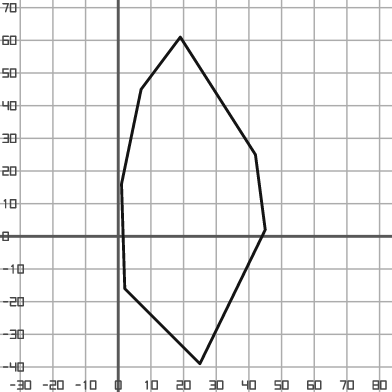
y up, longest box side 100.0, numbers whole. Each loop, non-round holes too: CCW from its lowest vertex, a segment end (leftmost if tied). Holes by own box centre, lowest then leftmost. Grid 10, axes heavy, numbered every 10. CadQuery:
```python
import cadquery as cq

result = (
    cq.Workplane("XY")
    .moveTo(25.0, -39.0)
    .lineTo(45.0, 2.0)
    .lineTo(42.0, 25.0)
    .lineTo(19.0, 61.0)
    .lineTo(7.0, 45.0)
    .lineTo(1.0, 16.0)
    .lineTo(2.0, -16.0)
    .close()
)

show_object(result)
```